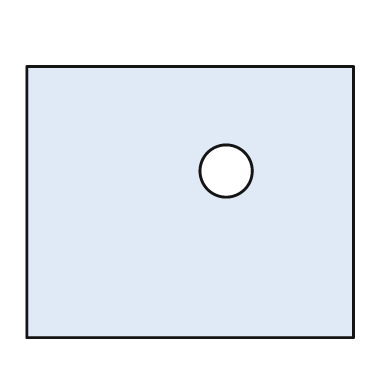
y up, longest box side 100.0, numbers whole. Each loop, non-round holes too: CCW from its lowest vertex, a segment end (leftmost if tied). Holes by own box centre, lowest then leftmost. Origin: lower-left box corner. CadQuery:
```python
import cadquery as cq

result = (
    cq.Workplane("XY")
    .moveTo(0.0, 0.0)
    .lineTo(100.0, 0.0)
    .lineTo(100.0, 83.0)
    .lineTo(0.0, 83.0)
    .close()
    .moveTo(61.0, 51.0)
    .circle(8.0)
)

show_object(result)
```